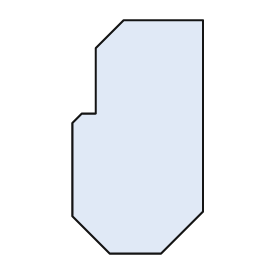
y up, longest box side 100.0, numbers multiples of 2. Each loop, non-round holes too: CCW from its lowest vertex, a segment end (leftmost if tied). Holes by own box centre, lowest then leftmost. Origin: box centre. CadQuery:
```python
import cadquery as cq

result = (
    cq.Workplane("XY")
    .moveTo(-12.0, -50.0)
    .lineTo(10.0, -50.0)
    .lineTo(28.0, -32.0)
    .lineTo(28.0, 50.0)
    .lineTo(-6.0, 50.0)
    .lineTo(-18.0, 38.0)
    .lineTo(-18.0, 10.0)
    .lineTo(-24.0, 10.0)
    .lineTo(-28.0, 6.0)
    .lineTo(-28.0, -34.0)
    .close()
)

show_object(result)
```